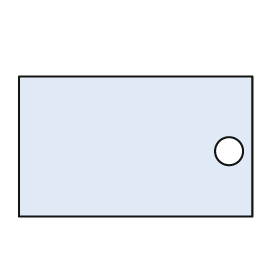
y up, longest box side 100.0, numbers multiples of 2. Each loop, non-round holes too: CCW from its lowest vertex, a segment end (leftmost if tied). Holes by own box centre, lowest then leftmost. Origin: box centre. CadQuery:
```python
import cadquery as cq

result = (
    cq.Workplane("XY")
    .moveTo(-50.0, -30.0)
    .lineTo(50.0, -30.0)
    .lineTo(50.0, 30.0)
    .lineTo(-50.0, 30.0)
    .close()
    .moveTo(40.0, -2.0)
    .circle(6.0)
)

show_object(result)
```